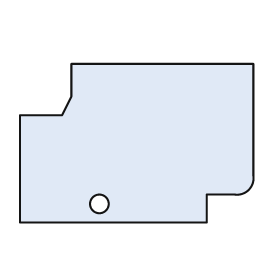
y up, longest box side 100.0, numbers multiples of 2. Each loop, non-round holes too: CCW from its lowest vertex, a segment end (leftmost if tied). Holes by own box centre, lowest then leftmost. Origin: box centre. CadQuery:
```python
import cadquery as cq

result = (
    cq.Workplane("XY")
    .moveTo(-50.0, -34.0)
    .lineTo(30.0, -34.0)
    .lineTo(30.0, -22.0)
    .lineTo(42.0, -22.0)
    .threePointArc((48.0, -20.0), (50.0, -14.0))
    .lineTo(50.0, 34.0)
    .lineTo(-28.0, 34.0)
    .lineTo(-28.0, 20.0)
    .lineTo(-32.0, 12.0)
    .lineTo(-50.0, 12.0)
    .close()
    .moveTo(-16.0, -26.0)
    .circle(4.0)
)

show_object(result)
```